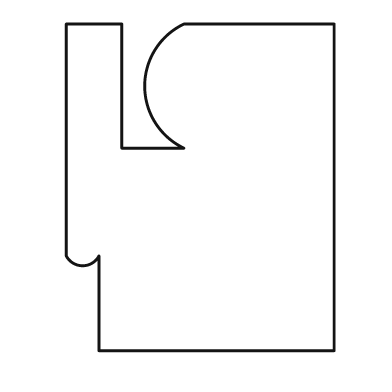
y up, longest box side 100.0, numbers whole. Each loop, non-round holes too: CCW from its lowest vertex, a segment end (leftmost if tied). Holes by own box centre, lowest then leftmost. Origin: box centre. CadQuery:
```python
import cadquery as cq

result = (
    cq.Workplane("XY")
    .moveTo(-31.0, -50.0)
    .lineTo(41.0, -50.0)
    .lineTo(41.0, 50.0)
    .lineTo(-5.0, 50.0)
    .threePointArc((-17.0, 31.0), (-5.0, 12.0))
    .lineTo(-24.0, 12.0)
    .lineTo(-24.0, 50.0)
    .lineTo(-41.0, 50.0)
    .lineTo(-41.0, -21.0)
    .threePointArc((-36.0, -24.0), (-31.0, -21.0))
    .close()
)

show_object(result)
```